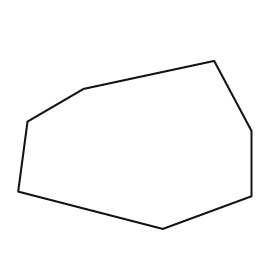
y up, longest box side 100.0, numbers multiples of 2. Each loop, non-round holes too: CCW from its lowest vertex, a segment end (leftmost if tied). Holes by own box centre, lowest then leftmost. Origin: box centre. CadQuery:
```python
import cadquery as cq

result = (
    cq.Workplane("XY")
    .moveTo(12.0, -36.0)
    .lineTo(50.0, -22.0)
    .lineTo(50.0, 6.0)
    .lineTo(34.0, 36.0)
    .lineTo(-22.0, 24.0)
    .lineTo(-46.0, 10.0)
    .lineTo(-50.0, -20.0)
    .close()
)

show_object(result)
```